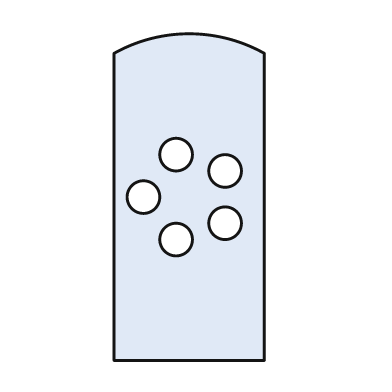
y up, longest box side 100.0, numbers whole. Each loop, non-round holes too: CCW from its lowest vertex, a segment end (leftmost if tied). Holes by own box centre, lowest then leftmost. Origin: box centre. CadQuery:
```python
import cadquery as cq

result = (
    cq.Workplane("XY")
    .moveTo(-23.0, -50.0)
    .lineTo(23.0, -50.0)
    .lineTo(23.0, 44.0)
    .threePointArc((0.0, 50.0), (-23.0, 44.0))
    .close()
    .moveTo(-4.0, -13.0)
    .circle(5.0)
    .moveTo(11.0, -8.0)
    .circle(5.0)
    .moveTo(-14.0, 0.0)
    .circle(5.0)
    .moveTo(11.0, 8.0)
    .circle(5.0)
    .moveTo(-4.0, 13.0)
    .circle(5.0)
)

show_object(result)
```